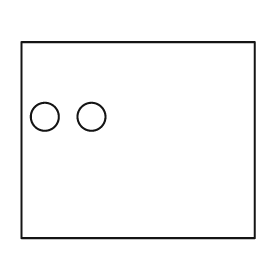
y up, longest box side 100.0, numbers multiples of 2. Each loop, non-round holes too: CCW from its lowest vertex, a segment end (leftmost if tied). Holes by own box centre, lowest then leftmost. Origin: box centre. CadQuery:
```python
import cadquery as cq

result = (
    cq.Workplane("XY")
    .moveTo(-50.0, -42.0)
    .lineTo(50.0, -42.0)
    .lineTo(50.0, 42.0)
    .lineTo(-50.0, 42.0)
    .close()
    .moveTo(-40.0, 10.0)
    .circle(6.0)
    .moveTo(-20.0, 10.0)
    .circle(6.0)
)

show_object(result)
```